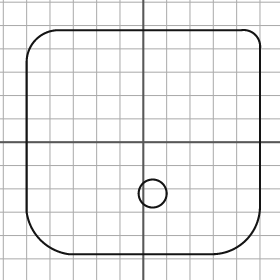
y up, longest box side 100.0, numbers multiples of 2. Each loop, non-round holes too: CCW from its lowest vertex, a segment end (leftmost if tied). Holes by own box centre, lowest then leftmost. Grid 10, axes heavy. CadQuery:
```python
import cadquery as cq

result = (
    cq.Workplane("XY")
    .moveTo(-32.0, -48.0)
    .lineTo(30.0, -48.0)
    .threePointArc((44.0, -42.0), (50.0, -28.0))
    .lineTo(50.0, 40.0)
    .threePointArc((48.0, 46.0), (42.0, 48.0))
    .lineTo(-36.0, 48.0)
    .threePointArc((-46.0, 44.0), (-50.0, 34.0))
    .lineTo(-50.0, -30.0)
    .threePointArc((-44.0, -42.0), (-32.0, -48.0))
    .close()
    .moveTo(4.0, -22.0)
    .circle(6.0)
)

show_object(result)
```